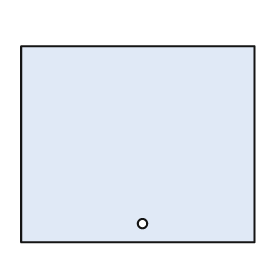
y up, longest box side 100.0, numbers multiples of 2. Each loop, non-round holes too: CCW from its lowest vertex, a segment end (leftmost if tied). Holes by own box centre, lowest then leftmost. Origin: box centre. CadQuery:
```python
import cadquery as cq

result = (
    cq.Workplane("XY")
    .moveTo(-50.0, -42.0)
    .lineTo(50.0, -42.0)
    .lineTo(50.0, 42.0)
    .lineTo(-50.0, 42.0)
    .close()
    .moveTo(2.0, -34.0)
    .circle(2.0)
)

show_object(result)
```